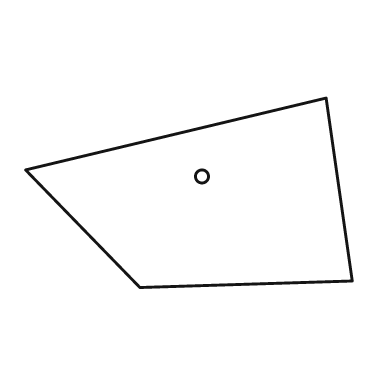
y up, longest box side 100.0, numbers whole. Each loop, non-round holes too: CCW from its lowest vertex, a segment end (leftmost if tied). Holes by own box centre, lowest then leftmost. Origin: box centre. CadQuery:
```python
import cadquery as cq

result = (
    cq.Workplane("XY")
    .moveTo(-15.0, -29.0)
    .lineTo(50.0, -27.0)
    .lineTo(42.0, 29.0)
    .lineTo(-50.0, 7.0)
    .close()
    .moveTo(4.0, 5.0)
    .circle(2.0)
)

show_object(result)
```